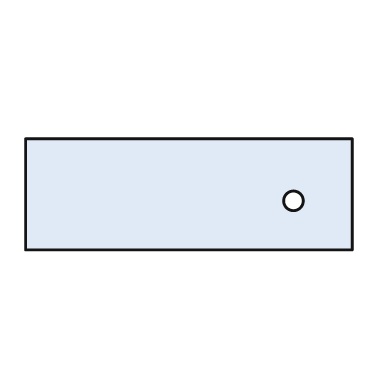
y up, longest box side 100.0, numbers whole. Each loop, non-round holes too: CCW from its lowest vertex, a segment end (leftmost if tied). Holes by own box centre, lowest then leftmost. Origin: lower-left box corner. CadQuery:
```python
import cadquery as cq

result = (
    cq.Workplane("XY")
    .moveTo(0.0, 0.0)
    .lineTo(100.0, 0.0)
    .lineTo(100.0, 34.0)
    .lineTo(0.0, 34.0)
    .close()
    .moveTo(82.0, 15.0)
    .circle(3.0)
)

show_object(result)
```